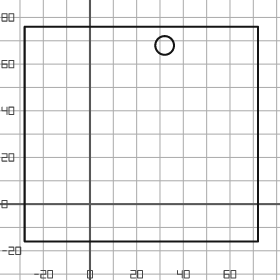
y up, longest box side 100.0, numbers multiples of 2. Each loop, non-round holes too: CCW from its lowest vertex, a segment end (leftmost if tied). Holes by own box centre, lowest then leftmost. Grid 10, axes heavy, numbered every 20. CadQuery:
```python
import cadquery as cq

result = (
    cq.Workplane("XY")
    .moveTo(-28.0, -16.0)
    .lineTo(72.0, -16.0)
    .lineTo(72.0, 76.0)
    .lineTo(-28.0, 76.0)
    .close()
    .moveTo(32.0, 68.0)
    .circle(4.0)
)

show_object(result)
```